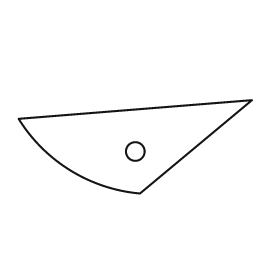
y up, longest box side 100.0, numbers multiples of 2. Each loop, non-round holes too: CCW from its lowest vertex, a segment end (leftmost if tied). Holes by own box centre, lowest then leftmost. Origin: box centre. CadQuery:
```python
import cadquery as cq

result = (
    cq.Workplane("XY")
    .moveTo(2.0, -20.0)
    .lineTo(50.0, 20.0)
    .lineTo(-50.0, 12.0)
    .threePointArc((-28.0, -10.0), (2.0, -20.0))
    .close()
    .moveTo(0.0, -2.0)
    .circle(4.0)
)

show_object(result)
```